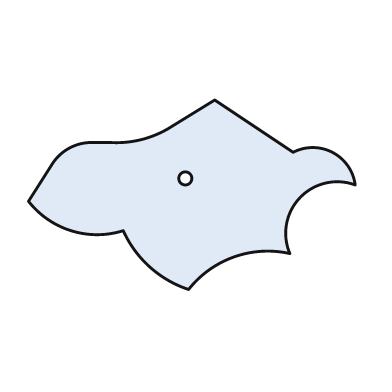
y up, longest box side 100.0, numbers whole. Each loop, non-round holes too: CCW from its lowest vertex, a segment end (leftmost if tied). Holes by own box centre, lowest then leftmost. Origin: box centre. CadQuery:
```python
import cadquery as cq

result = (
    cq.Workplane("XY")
    .moveTo(-1.0, -29.0)
    .threePointArc((13.0, -19.0), (30.0, -18.0))
    .threePointArc((33.0, -1.0), (50.0, 3.0))
    .threePointArc((43.0, 13.0), (31.0, 13.0))
    .lineTo(7.0, 29.0)
    .lineTo(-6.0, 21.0)
    .threePointArc((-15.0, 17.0), (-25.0, 16.0))
    .lineTo(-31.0, 16.0)
    .threePointArc((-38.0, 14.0), (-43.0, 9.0))
    .lineTo(-50.0, -2.0)
    .threePointArc((-37.0, -11.0), (-21.0, -11.0))
    .threePointArc((-13.0, -22.0), (-1.0, -29.0))
    .close()
    .moveTo(-2.0, 5.0)
    .circle(2.0)
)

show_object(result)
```